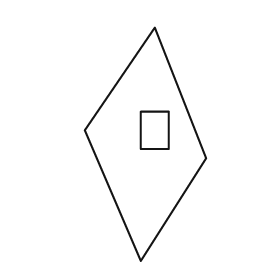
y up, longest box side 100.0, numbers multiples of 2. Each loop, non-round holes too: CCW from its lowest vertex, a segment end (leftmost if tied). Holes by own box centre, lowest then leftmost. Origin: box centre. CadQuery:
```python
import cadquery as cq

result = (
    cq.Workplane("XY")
    .moveTo(-2.0, -50.0)
    .lineTo(26.0, -6.0)
    .lineTo(4.0, 50.0)
    .lineTo(-26.0, 6.0)
    .close()
    .moveTo(-2.0, -2.0)
    .lineTo(10.0, -2.0)
    .lineTo(10.0, 14.0)
    .lineTo(-2.0, 14.0)
    .close()
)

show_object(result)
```